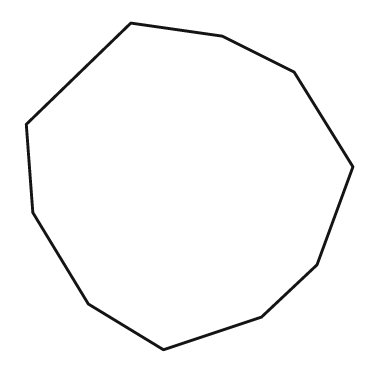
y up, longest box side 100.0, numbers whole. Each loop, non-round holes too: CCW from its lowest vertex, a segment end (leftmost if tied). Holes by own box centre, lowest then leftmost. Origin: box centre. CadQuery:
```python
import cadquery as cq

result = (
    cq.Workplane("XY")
    .moveTo(-8.0, -50.0)
    .lineTo(22.0, -40.0)
    .lineTo(39.0, -24.0)
    .lineTo(50.0, 6.0)
    .lineTo(32.0, 35.0)
    .lineTo(10.0, 46.0)
    .lineTo(-18.0, 50.0)
    .lineTo(-50.0, 19.0)
    .lineTo(-48.0, -8.0)
    .lineTo(-31.0, -36.0)
    .close()
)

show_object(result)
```